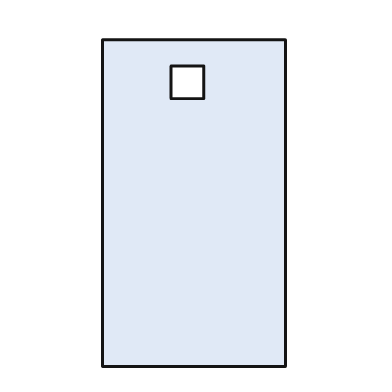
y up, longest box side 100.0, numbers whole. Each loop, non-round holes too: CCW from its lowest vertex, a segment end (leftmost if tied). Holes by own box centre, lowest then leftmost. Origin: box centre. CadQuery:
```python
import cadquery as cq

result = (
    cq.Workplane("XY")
    .moveTo(-28.0, -50.0)
    .lineTo(28.0, -50.0)
    .lineTo(28.0, 50.0)
    .lineTo(-28.0, 50.0)
    .close()
    .moveTo(-7.0, 32.0)
    .lineTo(3.0, 32.0)
    .lineTo(3.0, 42.0)
    .lineTo(-7.0, 42.0)
    .close()
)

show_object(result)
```